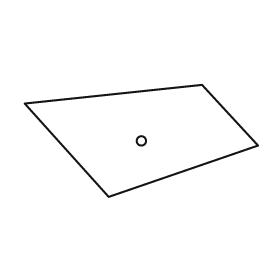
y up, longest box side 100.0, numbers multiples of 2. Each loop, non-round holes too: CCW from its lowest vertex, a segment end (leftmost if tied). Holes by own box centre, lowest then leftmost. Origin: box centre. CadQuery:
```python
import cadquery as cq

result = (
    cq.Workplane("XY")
    .moveTo(-14.0, -24.0)
    .lineTo(50.0, -2.0)
    .lineTo(26.0, 24.0)
    .lineTo(-50.0, 16.0)
    .close()
    .moveTo(0.0, 0.0)
    .circle(2.0)
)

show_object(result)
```